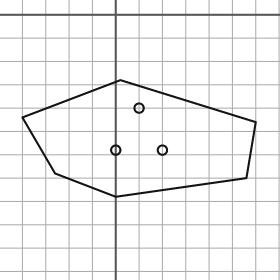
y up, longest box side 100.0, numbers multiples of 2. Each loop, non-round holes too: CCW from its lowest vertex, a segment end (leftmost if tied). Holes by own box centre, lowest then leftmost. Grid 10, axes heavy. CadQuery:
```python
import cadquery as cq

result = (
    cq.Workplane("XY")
    .moveTo(0.0, -78.0)
    .lineTo(56.0, -70.0)
    .lineTo(60.0, -46.0)
    .lineTo(2.0, -28.0)
    .lineTo(-40.0, -44.0)
    .lineTo(-26.0, -68.0)
    .close()
    .moveTo(0.0, -58.0)
    .circle(2.0)
    .moveTo(20.0, -58.0)
    .circle(2.0)
    .moveTo(10.0, -40.0)
    .circle(2.0)
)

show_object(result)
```